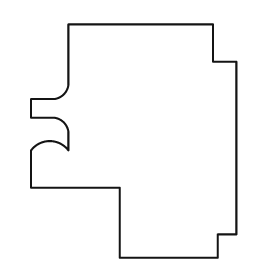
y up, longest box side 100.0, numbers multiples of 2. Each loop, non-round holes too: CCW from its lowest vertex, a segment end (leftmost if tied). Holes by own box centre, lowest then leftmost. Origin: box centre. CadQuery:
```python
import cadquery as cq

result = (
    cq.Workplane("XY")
    .moveTo(-6.0, -50.0)
    .lineTo(36.0, -50.0)
    .lineTo(36.0, -40.0)
    .lineTo(44.0, -40.0)
    .lineTo(44.0, 34.0)
    .lineTo(34.0, 34.0)
    .lineTo(34.0, 50.0)
    .lineTo(-28.0, 50.0)
    .lineTo(-28.0, 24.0)
    .threePointArc((-30.0, 20.0), (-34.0, 18.0))
    .lineTo(-44.0, 18.0)
    .lineTo(-44.0, 10.0)
    .lineTo(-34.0, 10.0)
    .threePointArc((-30.0, 8.0), (-28.0, 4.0))
    .lineTo(-28.0, -4.0)
    .threePointArc((-36.0, 0.0), (-44.0, -4.0))
    .lineTo(-44.0, -20.0)
    .lineTo(-6.0, -20.0)
    .close()
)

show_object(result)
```